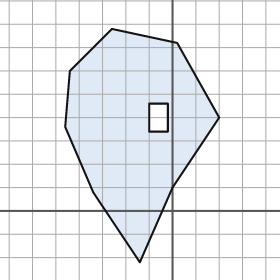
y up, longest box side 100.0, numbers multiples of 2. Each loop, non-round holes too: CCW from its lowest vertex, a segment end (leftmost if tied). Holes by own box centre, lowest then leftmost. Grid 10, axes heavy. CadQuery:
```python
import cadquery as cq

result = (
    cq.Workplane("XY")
    .moveTo(-14.0, -22.0)
    .lineTo(0.0, 10.0)
    .lineTo(20.0, 40.0)
    .lineTo(2.0, 72.0)
    .lineTo(-26.0, 78.0)
    .lineTo(-44.0, 60.0)
    .lineTo(-46.0, 36.0)
    .lineTo(-34.0, 8.0)
    .close()
    .moveTo(-10.0, 34.0)
    .lineTo(-2.0, 34.0)
    .lineTo(-2.0, 46.0)
    .lineTo(-10.0, 46.0)
    .close()
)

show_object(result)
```